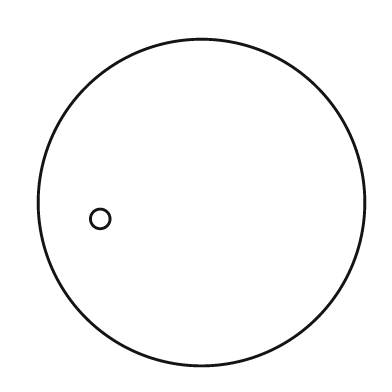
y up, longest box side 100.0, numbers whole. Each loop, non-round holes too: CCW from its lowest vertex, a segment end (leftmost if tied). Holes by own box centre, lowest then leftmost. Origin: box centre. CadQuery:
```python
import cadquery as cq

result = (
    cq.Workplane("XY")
    .moveTo(0.0, 0.0)
    .circle(50.0)
    .moveTo(-31.0, -5.0)
    .circle(3.0)
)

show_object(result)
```